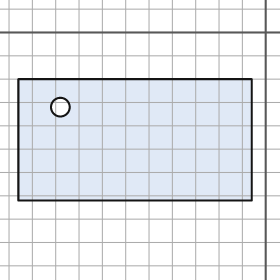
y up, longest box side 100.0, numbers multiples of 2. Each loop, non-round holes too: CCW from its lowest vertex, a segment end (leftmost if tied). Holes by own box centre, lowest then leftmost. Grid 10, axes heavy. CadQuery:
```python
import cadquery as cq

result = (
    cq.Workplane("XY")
    .moveTo(-106.0, -72.0)
    .lineTo(-6.0, -72.0)
    .lineTo(-6.0, -20.0)
    .lineTo(-106.0, -20.0)
    .close()
    .moveTo(-88.0, -32.0)
    .circle(4.0)
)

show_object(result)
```